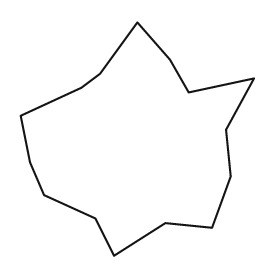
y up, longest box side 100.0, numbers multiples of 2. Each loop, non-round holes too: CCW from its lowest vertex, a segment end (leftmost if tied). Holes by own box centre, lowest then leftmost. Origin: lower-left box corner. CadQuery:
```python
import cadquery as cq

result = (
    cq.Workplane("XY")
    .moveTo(40.0, 0.0)
    .lineTo(62.0, 14.0)
    .lineTo(82.0, 12.0)
    .lineTo(90.0, 34.0)
    .lineTo(88.0, 54.0)
    .lineTo(100.0, 76.0)
    .lineTo(72.0, 70.0)
    .lineTo(64.0, 84.0)
    .lineTo(50.0, 100.0)
    .lineTo(34.0, 78.0)
    .lineTo(26.0, 72.0)
    .lineTo(0.0, 60.0)
    .lineTo(4.0, 40.0)
    .lineTo(10.0, 26.0)
    .lineTo(32.0, 16.0)
    .close()
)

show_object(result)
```